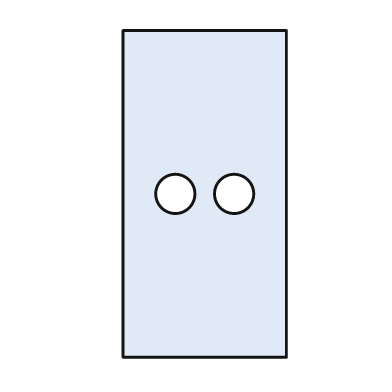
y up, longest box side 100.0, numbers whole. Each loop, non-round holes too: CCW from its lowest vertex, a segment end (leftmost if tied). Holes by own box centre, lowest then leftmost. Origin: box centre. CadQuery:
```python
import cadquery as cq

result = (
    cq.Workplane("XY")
    .moveTo(-25.0, -50.0)
    .lineTo(25.0, -50.0)
    .lineTo(25.0, 50.0)
    .lineTo(-25.0, 50.0)
    .close()
    .moveTo(-9.0, 0.0)
    .circle(6.0)
    .moveTo(9.0, 0.0)
    .circle(6.0)
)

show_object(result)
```